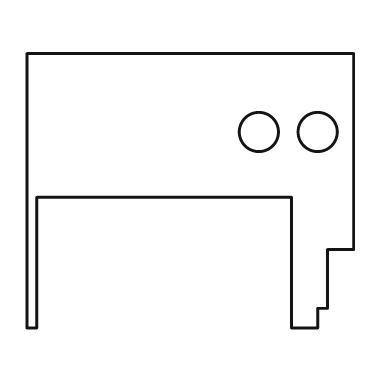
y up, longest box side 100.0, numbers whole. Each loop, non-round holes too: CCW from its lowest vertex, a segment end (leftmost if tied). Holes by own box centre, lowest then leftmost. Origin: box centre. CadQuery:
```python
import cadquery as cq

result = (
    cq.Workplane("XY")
    .moveTo(-50.0, -42.0)
    .lineTo(-47.0, -42.0)
    .lineTo(-47.0, -2.0)
    .lineTo(31.0, -2.0)
    .lineTo(31.0, -42.0)
    .lineTo(39.0, -42.0)
    .lineTo(39.0, -36.0)
    .lineTo(42.0, -36.0)
    .lineTo(42.0, -18.0)
    .lineTo(50.0, -18.0)
    .lineTo(50.0, 42.0)
    .lineTo(-50.0, 42.0)
    .close()
    .moveTo(21.0, 18.0)
    .circle(6.0)
    .moveTo(39.0, 18.0)
    .circle(6.0)
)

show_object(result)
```